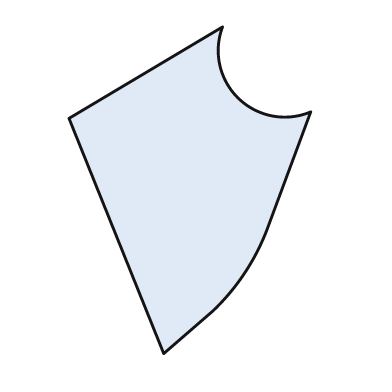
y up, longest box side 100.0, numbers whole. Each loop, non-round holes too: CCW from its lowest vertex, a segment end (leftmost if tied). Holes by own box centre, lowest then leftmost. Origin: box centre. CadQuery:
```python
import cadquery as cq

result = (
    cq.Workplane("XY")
    .moveTo(-8.0, -50.0)
    .lineTo(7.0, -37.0)
    .threePointArc((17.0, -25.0), (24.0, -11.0))
    .lineTo(37.0, 24.0)
    .threePointArc((15.0, 28.0), (10.0, 50.0))
    .lineTo(-37.0, 22.0)
    .close()
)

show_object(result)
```